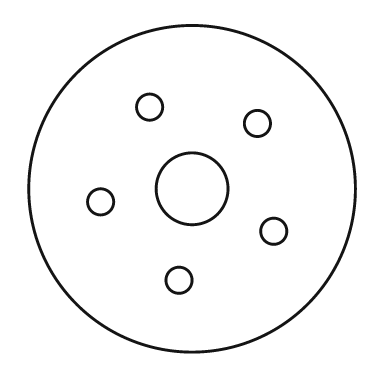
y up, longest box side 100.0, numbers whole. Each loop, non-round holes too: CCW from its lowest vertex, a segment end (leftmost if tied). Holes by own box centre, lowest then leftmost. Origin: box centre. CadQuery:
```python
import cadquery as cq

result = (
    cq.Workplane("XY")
    .moveTo(0.0, 0.0)
    .circle(50.0)
    .moveTo(-4.0, -28.0)
    .circle(4.0)
    .moveTo(25.0, -13.0)
    .circle(4.0)
    .moveTo(-28.0, -4.0)
    .circle(4.0)
    .moveTo(0.0, 0.0)
    .circle(11.0)
    .moveTo(20.0, 20.0)
    .circle(4.0)
    .moveTo(-13.0, 25.0)
    .circle(4.0)
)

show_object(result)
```